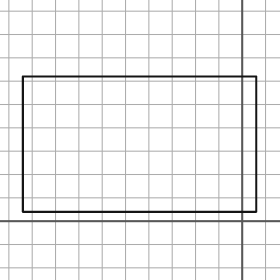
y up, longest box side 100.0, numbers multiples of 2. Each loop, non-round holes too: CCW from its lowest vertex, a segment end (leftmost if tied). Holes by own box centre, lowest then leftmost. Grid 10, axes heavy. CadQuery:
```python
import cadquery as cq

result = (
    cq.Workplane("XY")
    .moveTo(-94.0, 4.0)
    .lineTo(6.0, 4.0)
    .lineTo(6.0, 62.0)
    .lineTo(-94.0, 62.0)
    .close()
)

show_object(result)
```